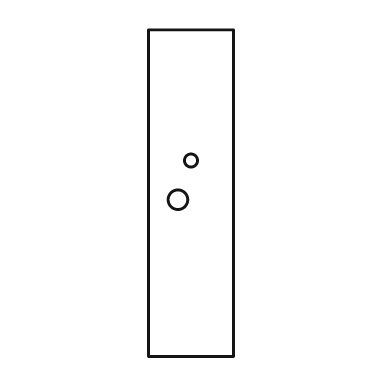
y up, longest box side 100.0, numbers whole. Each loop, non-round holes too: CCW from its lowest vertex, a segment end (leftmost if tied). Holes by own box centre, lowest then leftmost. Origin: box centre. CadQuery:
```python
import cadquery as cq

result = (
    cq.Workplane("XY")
    .moveTo(-13.0, -50.0)
    .lineTo(13.0, -50.0)
    .lineTo(13.0, 50.0)
    .lineTo(-13.0, 50.0)
    .close()
    .moveTo(-4.0, -2.0)
    .circle(3.0)
    .moveTo(0.0, 10.0)
    .circle(2.0)
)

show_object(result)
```